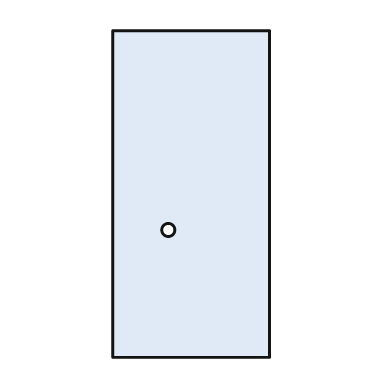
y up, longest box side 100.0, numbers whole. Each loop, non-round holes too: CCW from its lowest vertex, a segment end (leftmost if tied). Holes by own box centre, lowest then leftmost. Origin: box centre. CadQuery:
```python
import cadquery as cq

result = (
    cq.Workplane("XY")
    .moveTo(-24.0, -50.0)
    .lineTo(24.0, -50.0)
    .lineTo(24.0, 50.0)
    .lineTo(-24.0, 50.0)
    .close()
    .moveTo(-7.0, -11.0)
    .circle(2.0)
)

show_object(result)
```